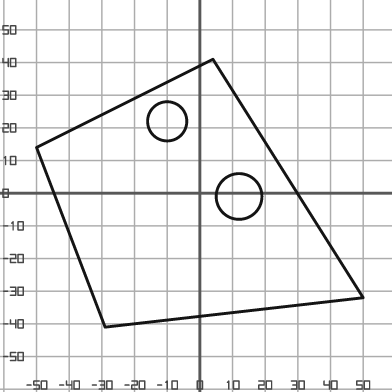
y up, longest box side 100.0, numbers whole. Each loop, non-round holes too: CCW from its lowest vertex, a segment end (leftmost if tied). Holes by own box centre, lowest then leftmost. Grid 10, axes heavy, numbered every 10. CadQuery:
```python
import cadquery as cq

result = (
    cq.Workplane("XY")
    .moveTo(-29.0, -41.0)
    .lineTo(50.0, -32.0)
    .lineTo(4.0, 41.0)
    .lineTo(-50.0, 14.0)
    .close()
    .moveTo(12.0, -1.0)
    .circle(7.0)
    .moveTo(-10.0, 22.0)
    .circle(6.0)
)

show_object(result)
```